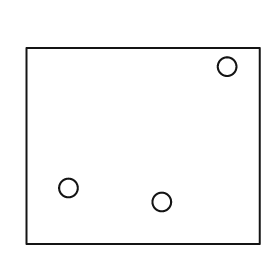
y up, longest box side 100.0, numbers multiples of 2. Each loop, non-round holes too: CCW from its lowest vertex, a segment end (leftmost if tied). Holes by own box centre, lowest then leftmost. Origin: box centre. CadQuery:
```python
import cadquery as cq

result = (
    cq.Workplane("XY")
    .moveTo(-50.0, -42.0)
    .lineTo(50.0, -42.0)
    .lineTo(50.0, 42.0)
    .lineTo(-50.0, 42.0)
    .close()
    .moveTo(8.0, -24.0)
    .circle(4.0)
    .moveTo(-32.0, -18.0)
    .circle(4.0)
    .moveTo(36.0, 34.0)
    .circle(4.0)
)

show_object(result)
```